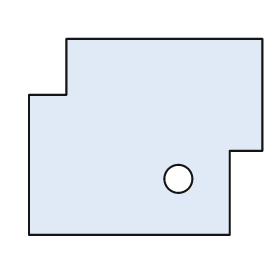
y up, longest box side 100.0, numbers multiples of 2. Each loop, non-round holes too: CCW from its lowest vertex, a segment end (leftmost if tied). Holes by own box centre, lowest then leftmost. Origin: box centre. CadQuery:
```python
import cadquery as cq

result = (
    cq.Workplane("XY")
    .moveTo(-50.0, -42.0)
    .lineTo(36.0, -42.0)
    .lineTo(36.0, -6.0)
    .lineTo(50.0, -6.0)
    .lineTo(50.0, 42.0)
    .lineTo(-34.0, 42.0)
    .lineTo(-34.0, 18.0)
    .lineTo(-50.0, 18.0)
    .close()
    .moveTo(14.0, -18.0)
    .circle(6.0)
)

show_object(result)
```